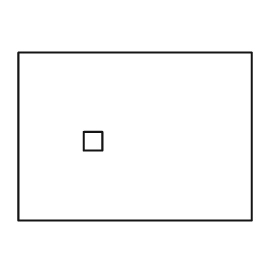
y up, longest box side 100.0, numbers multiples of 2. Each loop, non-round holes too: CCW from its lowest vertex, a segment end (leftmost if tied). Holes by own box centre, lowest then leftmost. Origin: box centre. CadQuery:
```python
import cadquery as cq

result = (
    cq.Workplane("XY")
    .moveTo(-50.0, -36.0)
    .lineTo(50.0, -36.0)
    .lineTo(50.0, 36.0)
    .lineTo(-50.0, 36.0)
    .close()
    .moveTo(-22.0, -6.0)
    .lineTo(-14.0, -6.0)
    .lineTo(-14.0, 2.0)
    .lineTo(-22.0, 2.0)
    .close()
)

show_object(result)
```